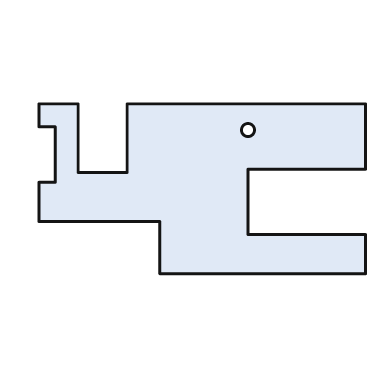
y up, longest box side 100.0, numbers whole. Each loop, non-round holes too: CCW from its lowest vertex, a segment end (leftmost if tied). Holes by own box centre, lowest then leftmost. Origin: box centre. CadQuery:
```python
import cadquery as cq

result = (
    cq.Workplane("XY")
    .moveTo(-13.0, -26.0)
    .lineTo(50.0, -26.0)
    .lineTo(50.0, -14.0)
    .lineTo(14.0, -14.0)
    .lineTo(14.0, 6.0)
    .lineTo(50.0, 6.0)
    .lineTo(50.0, 26.0)
    .lineTo(-23.0, 26.0)
    .lineTo(-23.0, 5.0)
    .lineTo(-38.0, 5.0)
    .lineTo(-38.0, 26.0)
    .lineTo(-50.0, 26.0)
    .lineTo(-50.0, 19.0)
    .lineTo(-45.0, 19.0)
    .lineTo(-45.0, 2.0)
    .lineTo(-50.0, 2.0)
    .lineTo(-50.0, -10.0)
    .lineTo(-13.0, -10.0)
    .close()
    .moveTo(14.0, 18.0)
    .circle(2.0)
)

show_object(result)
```